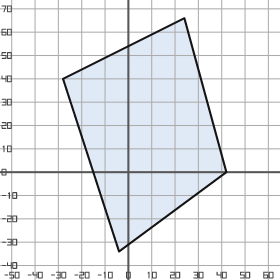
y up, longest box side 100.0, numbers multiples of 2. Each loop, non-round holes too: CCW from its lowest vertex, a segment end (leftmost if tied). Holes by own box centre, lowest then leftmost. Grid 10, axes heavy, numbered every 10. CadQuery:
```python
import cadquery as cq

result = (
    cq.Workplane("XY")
    .moveTo(-4.0, -34.0)
    .lineTo(42.0, 0.0)
    .lineTo(24.0, 66.0)
    .lineTo(-28.0, 40.0)
    .close()
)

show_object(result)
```